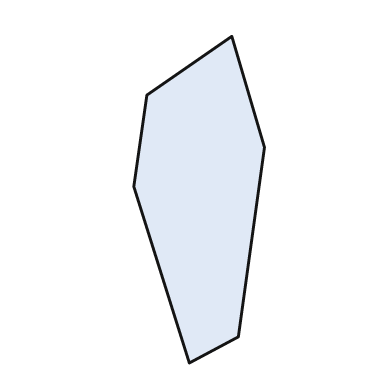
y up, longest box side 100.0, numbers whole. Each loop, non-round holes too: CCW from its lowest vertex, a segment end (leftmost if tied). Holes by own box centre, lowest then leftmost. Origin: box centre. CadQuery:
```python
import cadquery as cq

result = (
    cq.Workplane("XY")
    .moveTo(-3.0, -50.0)
    .lineTo(12.0, -42.0)
    .lineTo(20.0, 16.0)
    .lineTo(10.0, 50.0)
    .lineTo(-16.0, 32.0)
    .lineTo(-20.0, 4.0)
    .close()
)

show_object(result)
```